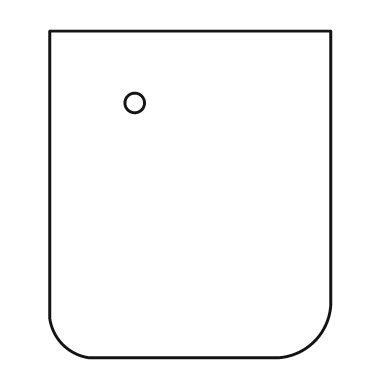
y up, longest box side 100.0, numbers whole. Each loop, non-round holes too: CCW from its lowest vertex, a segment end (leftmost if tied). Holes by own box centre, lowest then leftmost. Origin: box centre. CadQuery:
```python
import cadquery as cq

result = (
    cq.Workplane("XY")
    .moveTo(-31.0, -50.0)
    .lineTo(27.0, -50.0)
    .threePointArc((38.0, -45.0), (43.0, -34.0))
    .lineTo(43.0, 50.0)
    .lineTo(-43.0, 50.0)
    .lineTo(-43.0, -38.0)
    .threePointArc((-39.0, -46.0), (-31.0, -50.0))
    .close()
    .moveTo(-17.0, 28.0)
    .circle(3.0)
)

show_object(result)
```